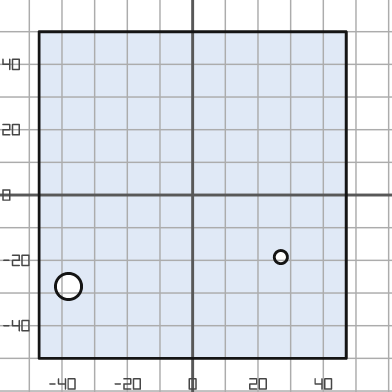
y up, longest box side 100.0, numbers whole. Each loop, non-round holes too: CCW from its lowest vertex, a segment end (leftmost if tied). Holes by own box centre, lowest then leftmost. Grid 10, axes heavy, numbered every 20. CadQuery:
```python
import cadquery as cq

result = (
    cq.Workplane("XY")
    .moveTo(-47.0, -50.0)
    .lineTo(47.0, -50.0)
    .lineTo(47.0, 50.0)
    .lineTo(-47.0, 50.0)
    .close()
    .moveTo(-38.0, -28.0)
    .circle(4.0)
    .moveTo(27.0, -19.0)
    .circle(2.0)
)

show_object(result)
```